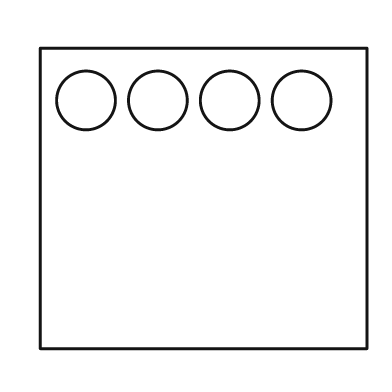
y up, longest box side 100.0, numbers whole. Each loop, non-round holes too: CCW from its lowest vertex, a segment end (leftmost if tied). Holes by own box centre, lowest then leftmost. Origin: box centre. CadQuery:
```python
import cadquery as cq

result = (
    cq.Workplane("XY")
    .moveTo(-50.0, -46.0)
    .lineTo(50.0, -46.0)
    .lineTo(50.0, 46.0)
    .lineTo(-50.0, 46.0)
    .close()
    .moveTo(-36.0, 30.0)
    .circle(9.0)
    .moveTo(-14.0, 30.0)
    .circle(9.0)
    .moveTo(8.0, 30.0)
    .circle(9.0)
    .moveTo(30.0, 30.0)
    .circle(9.0)
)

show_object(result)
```